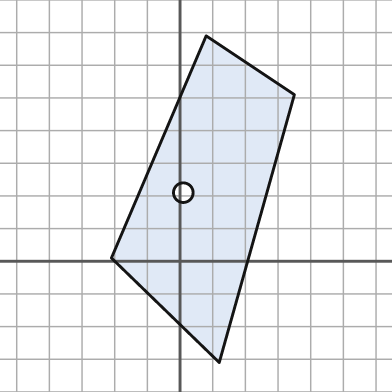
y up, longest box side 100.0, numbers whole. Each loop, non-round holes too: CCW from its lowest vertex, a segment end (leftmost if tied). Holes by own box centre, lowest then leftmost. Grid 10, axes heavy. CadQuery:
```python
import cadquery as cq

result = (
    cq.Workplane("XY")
    .moveTo(12.0, -31.0)
    .lineTo(35.0, 51.0)
    .lineTo(8.0, 69.0)
    .lineTo(-21.0, 1.0)
    .close()
    .moveTo(1.0, 21.0)
    .circle(3.0)
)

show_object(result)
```